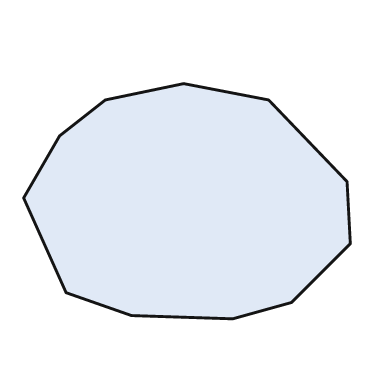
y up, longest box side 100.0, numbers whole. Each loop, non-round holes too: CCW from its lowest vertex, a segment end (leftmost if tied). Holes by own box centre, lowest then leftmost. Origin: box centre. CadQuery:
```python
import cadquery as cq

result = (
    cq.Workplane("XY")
    .moveTo(14.0, -36.0)
    .lineTo(32.0, -31.0)
    .lineTo(50.0, -13.0)
    .lineTo(49.0, 6.0)
    .lineTo(25.0, 31.0)
    .lineTo(-1.0, 36.0)
    .lineTo(-25.0, 31.0)
    .lineTo(-39.0, 20.0)
    .lineTo(-50.0, 1.0)
    .lineTo(-37.0, -28.0)
    .lineTo(-17.0, -35.0)
    .close()
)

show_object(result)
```